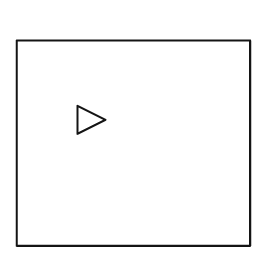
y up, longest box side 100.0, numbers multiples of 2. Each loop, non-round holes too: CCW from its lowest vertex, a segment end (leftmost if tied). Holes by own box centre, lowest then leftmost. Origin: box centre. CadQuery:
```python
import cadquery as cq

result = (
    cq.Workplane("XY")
    .moveTo(-50.0, -44.0)
    .lineTo(50.0, -44.0)
    .lineTo(50.0, 44.0)
    .lineTo(-50.0, 44.0)
    .close()
    .moveTo(-24.0, 4.0)
    .lineTo(-12.0, 10.0)
    .lineTo(-24.0, 16.0)
    .close()
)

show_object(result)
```